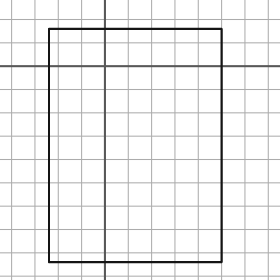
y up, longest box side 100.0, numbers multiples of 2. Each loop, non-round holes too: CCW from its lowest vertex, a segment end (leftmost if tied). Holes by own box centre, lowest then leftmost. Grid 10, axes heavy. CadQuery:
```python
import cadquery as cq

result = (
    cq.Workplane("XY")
    .moveTo(-24.0, -84.0)
    .lineTo(50.0, -84.0)
    .lineTo(50.0, 16.0)
    .lineTo(-24.0, 16.0)
    .close()
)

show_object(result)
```